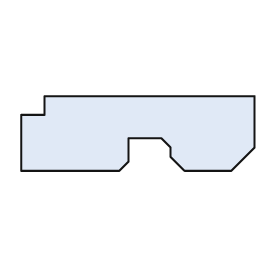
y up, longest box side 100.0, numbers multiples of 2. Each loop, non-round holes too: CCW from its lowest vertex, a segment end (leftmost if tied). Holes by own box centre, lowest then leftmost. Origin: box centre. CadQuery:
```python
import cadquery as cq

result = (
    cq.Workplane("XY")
    .moveTo(-50.0, -16.0)
    .lineTo(-8.0, -16.0)
    .lineTo(-4.0, -12.0)
    .lineTo(-4.0, -2.0)
    .lineTo(10.0, -2.0)
    .lineTo(14.0, -6.0)
    .lineTo(14.0, -10.0)
    .lineTo(20.0, -16.0)
    .lineTo(40.0, -16.0)
    .lineTo(50.0, -6.0)
    .lineTo(50.0, 16.0)
    .lineTo(-40.0, 16.0)
    .lineTo(-40.0, 8.0)
    .lineTo(-50.0, 8.0)
    .close()
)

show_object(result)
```